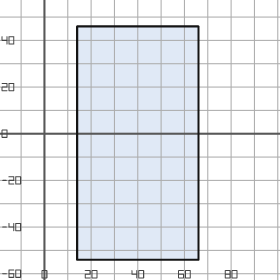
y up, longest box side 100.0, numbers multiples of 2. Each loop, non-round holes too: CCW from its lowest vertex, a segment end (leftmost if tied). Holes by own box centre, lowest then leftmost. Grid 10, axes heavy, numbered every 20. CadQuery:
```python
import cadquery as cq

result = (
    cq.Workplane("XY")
    .moveTo(14.0, -54.0)
    .lineTo(66.0, -54.0)
    .lineTo(66.0, 46.0)
    .lineTo(14.0, 46.0)
    .close()
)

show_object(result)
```